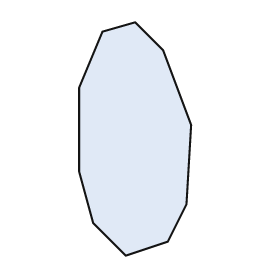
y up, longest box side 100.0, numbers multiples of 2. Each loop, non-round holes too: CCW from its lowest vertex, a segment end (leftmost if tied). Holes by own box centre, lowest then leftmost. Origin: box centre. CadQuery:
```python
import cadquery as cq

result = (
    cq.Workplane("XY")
    .moveTo(-4.0, -50.0)
    .lineTo(14.0, -44.0)
    .lineTo(22.0, -28.0)
    .lineTo(24.0, 6.0)
    .lineTo(12.0, 38.0)
    .lineTo(0.0, 50.0)
    .lineTo(-14.0, 46.0)
    .lineTo(-24.0, 22.0)
    .lineTo(-24.0, -14.0)
    .lineTo(-18.0, -36.0)
    .close()
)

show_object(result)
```